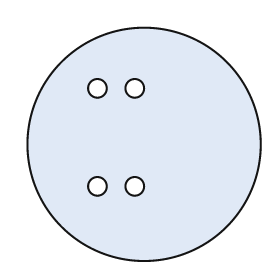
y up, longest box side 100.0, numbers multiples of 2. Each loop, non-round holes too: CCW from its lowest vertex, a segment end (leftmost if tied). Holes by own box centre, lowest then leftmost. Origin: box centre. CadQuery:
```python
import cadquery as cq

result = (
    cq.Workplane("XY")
    .moveTo(0.0, 0.0)
    .circle(50.0)
    .moveTo(-20.0, -18.0)
    .circle(4.0)
    .moveTo(-4.0, -18.0)
    .circle(4.0)
    .moveTo(-20.0, 24.0)
    .circle(4.0)
    .moveTo(-4.0, 24.0)
    .circle(4.0)
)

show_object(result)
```